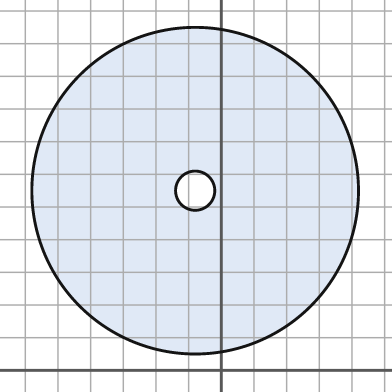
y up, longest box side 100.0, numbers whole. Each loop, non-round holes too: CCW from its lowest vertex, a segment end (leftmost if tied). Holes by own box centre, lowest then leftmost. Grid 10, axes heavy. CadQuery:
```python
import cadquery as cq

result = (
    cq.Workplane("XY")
    .moveTo(-8.0, 55.0)
    .circle(50.0)
    .moveTo(-8.0, 55.0)
    .circle(6.0)
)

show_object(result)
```